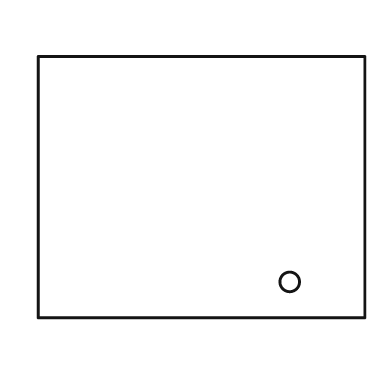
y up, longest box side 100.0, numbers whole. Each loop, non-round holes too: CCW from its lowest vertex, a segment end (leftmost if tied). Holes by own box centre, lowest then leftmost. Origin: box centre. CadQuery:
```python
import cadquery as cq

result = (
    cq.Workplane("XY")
    .moveTo(-50.0, -40.0)
    .lineTo(50.0, -40.0)
    .lineTo(50.0, 40.0)
    .lineTo(-50.0, 40.0)
    .close()
    .moveTo(27.0, -29.0)
    .circle(3.0)
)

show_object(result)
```